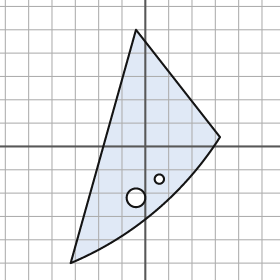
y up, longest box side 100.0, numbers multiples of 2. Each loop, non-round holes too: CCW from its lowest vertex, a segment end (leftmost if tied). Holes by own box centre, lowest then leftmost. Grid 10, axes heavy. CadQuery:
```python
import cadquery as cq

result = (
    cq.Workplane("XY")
    .moveTo(-32.0, -50.0)
    .threePointArc((4.0, -28.0), (32.0, 4.0))
    .lineTo(-4.0, 50.0)
    .close()
    .moveTo(-4.0, -22.0)
    .circle(4.0)
    .moveTo(6.0, -14.0)
    .circle(2.0)
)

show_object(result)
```